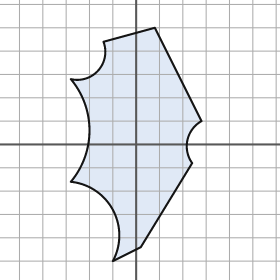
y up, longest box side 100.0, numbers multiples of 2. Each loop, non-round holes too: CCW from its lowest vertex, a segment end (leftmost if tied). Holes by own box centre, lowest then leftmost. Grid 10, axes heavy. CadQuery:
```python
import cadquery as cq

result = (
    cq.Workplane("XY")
    .moveTo(-10.0, -50.0)
    .lineTo(2.0, -44.0)
    .lineTo(24.0, -8.0)
    .threePointArc((22.0, 2.0), (28.0, 10.0))
    .lineTo(8.0, 50.0)
    .lineTo(-14.0, 44.0)
    .threePointArc((-16.0, 32.0), (-28.0, 28.0))
    .threePointArc((-20.0, 6.0), (-28.0, -16.0))
    .threePointArc((-10.0, -28.0), (-10.0, -50.0))
    .close()
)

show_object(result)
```